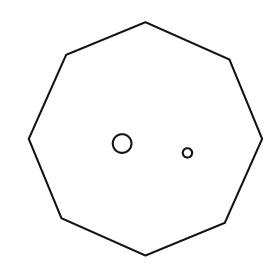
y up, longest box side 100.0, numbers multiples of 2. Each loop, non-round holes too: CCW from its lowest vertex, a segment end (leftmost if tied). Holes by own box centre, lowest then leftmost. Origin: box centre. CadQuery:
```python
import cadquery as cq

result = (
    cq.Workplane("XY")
    .moveTo(0.0, -50.0)
    .lineTo(34.0, -36.0)
    .lineTo(50.0, 0.0)
    .lineTo(36.0, 34.0)
    .lineTo(0.0, 50.0)
    .lineTo(-34.0, 36.0)
    .lineTo(-50.0, 0.0)
    .lineTo(-36.0, -34.0)
    .close()
    .moveTo(18.0, -6.0)
    .circle(2.0)
    .moveTo(-10.0, -2.0)
    .circle(4.0)
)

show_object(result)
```